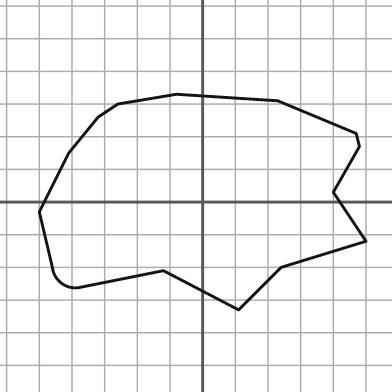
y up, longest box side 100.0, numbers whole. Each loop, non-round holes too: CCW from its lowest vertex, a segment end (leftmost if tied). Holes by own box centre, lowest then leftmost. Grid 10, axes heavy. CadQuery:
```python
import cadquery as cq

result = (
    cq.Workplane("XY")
    .moveTo(11.0, -33.0)
    .lineTo(24.0, -20.0)
    .lineTo(50.0, -12.0)
    .lineTo(40.0, 3.0)
    .lineTo(48.0, 17.0)
    .lineTo(47.0, 21.0)
    .lineTo(23.0, 31.0)
    .lineTo(-8.0, 33.0)
    .lineTo(-26.0, 30.0)
    .lineTo(-32.0, 26.0)
    .lineTo(-41.0, 15.0)
    .lineTo(-50.0, -3.0)
    .lineTo(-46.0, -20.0)
    .threePointArc((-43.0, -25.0), (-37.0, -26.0))
    .lineTo(-12.0, -21.0)
    .close()
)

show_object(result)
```